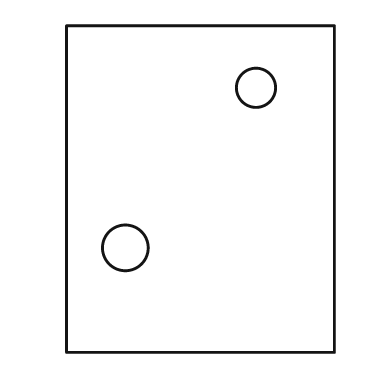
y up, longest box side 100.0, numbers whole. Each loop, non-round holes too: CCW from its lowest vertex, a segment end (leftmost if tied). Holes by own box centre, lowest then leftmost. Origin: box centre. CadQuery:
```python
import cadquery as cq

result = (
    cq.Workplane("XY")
    .moveTo(-41.0, -50.0)
    .lineTo(41.0, -50.0)
    .lineTo(41.0, 50.0)
    .lineTo(-41.0, 50.0)
    .close()
    .moveTo(-23.0, -18.0)
    .circle(7.0)
    .moveTo(17.0, 31.0)
    .circle(6.0)
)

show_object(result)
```